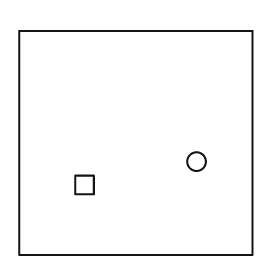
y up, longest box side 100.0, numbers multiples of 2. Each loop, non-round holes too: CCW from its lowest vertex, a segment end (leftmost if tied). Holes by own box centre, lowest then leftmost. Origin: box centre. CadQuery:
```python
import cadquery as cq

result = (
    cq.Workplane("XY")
    .moveTo(-50.0, -48.0)
    .lineTo(50.0, -48.0)
    .lineTo(50.0, 48.0)
    .lineTo(-50.0, 48.0)
    .close()
    .moveTo(-26.0, -22.0)
    .lineTo(-18.0, -22.0)
    .lineTo(-18.0, -14.0)
    .lineTo(-26.0, -14.0)
    .close()
    .moveTo(26.0, -8.0)
    .circle(4.0)
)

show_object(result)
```